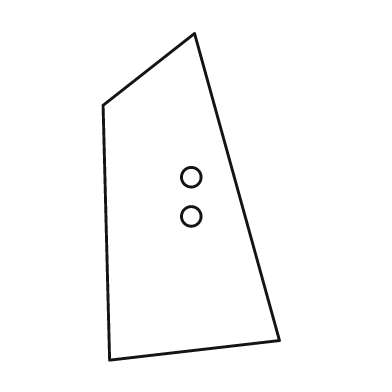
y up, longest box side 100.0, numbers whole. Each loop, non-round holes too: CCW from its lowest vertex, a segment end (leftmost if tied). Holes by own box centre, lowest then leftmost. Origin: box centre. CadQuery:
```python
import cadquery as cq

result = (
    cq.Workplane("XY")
    .moveTo(-25.0, -50.0)
    .lineTo(27.0, -44.0)
    .lineTo(1.0, 50.0)
    .lineTo(-27.0, 28.0)
    .close()
    .moveTo(0.0, -6.0)
    .circle(3.0)
    .moveTo(0.0, 6.0)
    .circle(3.0)
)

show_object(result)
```